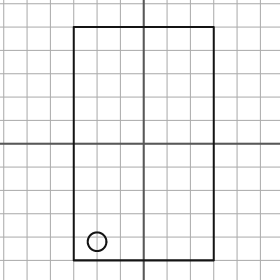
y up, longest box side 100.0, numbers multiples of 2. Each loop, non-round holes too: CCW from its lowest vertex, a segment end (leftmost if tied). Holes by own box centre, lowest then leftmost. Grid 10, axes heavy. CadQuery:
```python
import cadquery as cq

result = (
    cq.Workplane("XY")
    .moveTo(-30.0, -50.0)
    .lineTo(30.0, -50.0)
    .lineTo(30.0, 50.0)
    .lineTo(-30.0, 50.0)
    .close()
    .moveTo(-20.0, -42.0)
    .circle(4.0)
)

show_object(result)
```